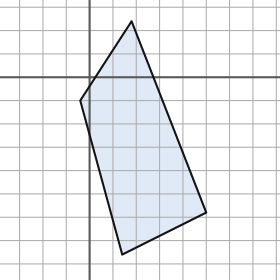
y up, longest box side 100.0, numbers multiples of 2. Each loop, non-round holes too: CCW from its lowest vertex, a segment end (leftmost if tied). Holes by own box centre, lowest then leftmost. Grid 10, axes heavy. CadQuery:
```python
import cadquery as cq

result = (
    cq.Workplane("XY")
    .moveTo(14.0, -76.0)
    .lineTo(50.0, -58.0)
    .lineTo(18.0, 24.0)
    .lineTo(-4.0, -10.0)
    .close()
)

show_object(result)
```